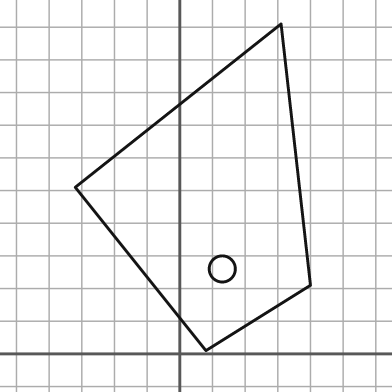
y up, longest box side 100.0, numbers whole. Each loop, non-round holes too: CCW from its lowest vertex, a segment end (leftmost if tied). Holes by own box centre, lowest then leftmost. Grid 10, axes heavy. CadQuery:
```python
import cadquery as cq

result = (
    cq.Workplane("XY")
    .moveTo(8.0, 1.0)
    .lineTo(40.0, 21.0)
    .lineTo(31.0, 101.0)
    .lineTo(-32.0, 51.0)
    .close()
    .moveTo(13.0, 26.0)
    .circle(4.0)
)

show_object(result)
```